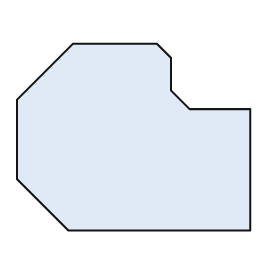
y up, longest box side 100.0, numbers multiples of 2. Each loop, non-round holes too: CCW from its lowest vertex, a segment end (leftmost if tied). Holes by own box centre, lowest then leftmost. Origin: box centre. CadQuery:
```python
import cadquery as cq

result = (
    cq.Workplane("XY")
    .moveTo(-28.0, -40.0)
    .lineTo(50.0, -40.0)
    .lineTo(50.0, 12.0)
    .lineTo(24.0, 12.0)
    .lineTo(16.0, 20.0)
    .lineTo(16.0, 34.0)
    .lineTo(10.0, 40.0)
    .lineTo(-26.0, 40.0)
    .lineTo(-50.0, 16.0)
    .lineTo(-50.0, -18.0)
    .close()
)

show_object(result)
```